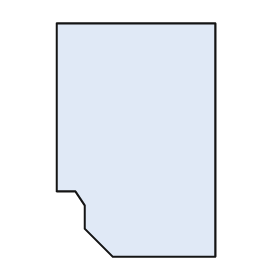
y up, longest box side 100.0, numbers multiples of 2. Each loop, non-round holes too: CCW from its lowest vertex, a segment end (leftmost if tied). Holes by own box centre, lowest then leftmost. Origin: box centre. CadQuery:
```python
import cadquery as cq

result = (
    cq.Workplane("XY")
    .moveTo(-10.0, -50.0)
    .lineTo(34.0, -50.0)
    .lineTo(34.0, 50.0)
    .lineTo(-34.0, 50.0)
    .lineTo(-34.0, -22.0)
    .lineTo(-26.0, -22.0)
    .lineTo(-22.0, -28.0)
    .lineTo(-22.0, -38.0)
    .close()
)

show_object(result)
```